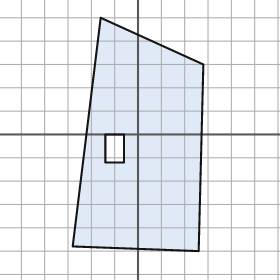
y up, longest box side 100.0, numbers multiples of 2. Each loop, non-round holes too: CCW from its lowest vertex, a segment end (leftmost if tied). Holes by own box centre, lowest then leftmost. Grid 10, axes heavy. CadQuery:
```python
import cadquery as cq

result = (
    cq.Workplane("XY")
    .moveTo(26.0, -50.0)
    .lineTo(28.0, 30.0)
    .lineTo(-16.0, 50.0)
    .lineTo(-28.0, -48.0)
    .close()
    .moveTo(-14.0, -12.0)
    .lineTo(-6.0, -12.0)
    .lineTo(-6.0, 0.0)
    .lineTo(-14.0, 0.0)
    .close()
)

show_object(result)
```